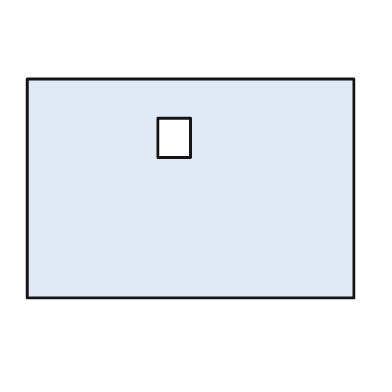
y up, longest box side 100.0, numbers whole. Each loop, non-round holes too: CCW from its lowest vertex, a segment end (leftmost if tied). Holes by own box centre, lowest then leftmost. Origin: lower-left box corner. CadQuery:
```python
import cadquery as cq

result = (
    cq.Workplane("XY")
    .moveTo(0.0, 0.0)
    .lineTo(100.0, 0.0)
    .lineTo(100.0, 67.0)
    .lineTo(0.0, 67.0)
    .close()
    .moveTo(40.0, 43.0)
    .lineTo(50.0, 43.0)
    .lineTo(50.0, 55.0)
    .lineTo(40.0, 55.0)
    .close()
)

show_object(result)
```